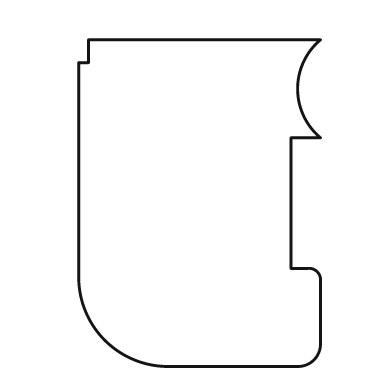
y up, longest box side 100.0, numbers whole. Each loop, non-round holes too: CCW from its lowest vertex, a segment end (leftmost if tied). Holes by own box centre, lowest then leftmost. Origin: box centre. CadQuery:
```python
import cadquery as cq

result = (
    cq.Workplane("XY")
    .moveTo(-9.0, -50.0)
    .lineTo(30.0, -50.0)
    .threePointArc((35.0, -48.0), (37.0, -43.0))
    .lineTo(37.0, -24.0)
    .threePointArc((36.0, -21.0), (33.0, -20.0))
    .lineTo(28.0, -20.0)
    .lineTo(28.0, 20.0)
    .lineTo(37.0, 20.0)
    .threePointArc((30.0, 35.0), (37.0, 50.0))
    .lineTo(-34.0, 50.0)
    .lineTo(-34.0, 43.0)
    .lineTo(-37.0, 43.0)
    .lineTo(-37.0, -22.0)
    .threePointArc((-29.0, -42.0), (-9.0, -50.0))
    .close()
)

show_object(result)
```